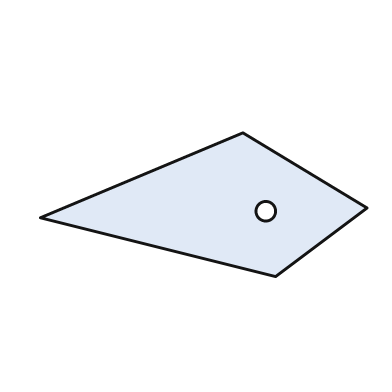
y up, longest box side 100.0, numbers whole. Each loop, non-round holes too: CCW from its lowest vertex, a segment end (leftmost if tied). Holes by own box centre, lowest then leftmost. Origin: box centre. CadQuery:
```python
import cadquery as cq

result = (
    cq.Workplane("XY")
    .moveTo(22.0, -22.0)
    .lineTo(50.0, -1.0)
    .lineTo(12.0, 22.0)
    .lineTo(-50.0, -4.0)
    .close()
    .moveTo(19.0, -2.0)
    .circle(3.0)
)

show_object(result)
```